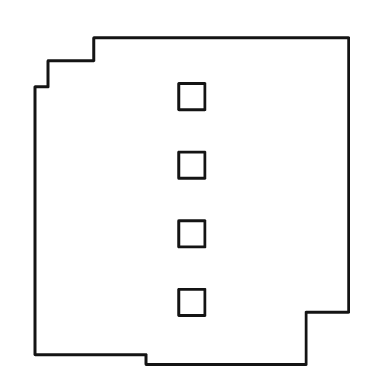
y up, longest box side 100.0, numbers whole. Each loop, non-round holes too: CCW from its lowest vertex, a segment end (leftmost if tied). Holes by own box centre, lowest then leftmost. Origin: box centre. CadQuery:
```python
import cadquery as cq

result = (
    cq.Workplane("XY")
    .moveTo(-14.0, -50.0)
    .lineTo(35.0, -50.0)
    .lineTo(35.0, -34.0)
    .lineTo(48.0, -34.0)
    .lineTo(48.0, 50.0)
    .lineTo(-30.0, 50.0)
    .lineTo(-30.0, 43.0)
    .lineTo(-44.0, 43.0)
    .lineTo(-44.0, 35.0)
    .lineTo(-48.0, 35.0)
    .lineTo(-48.0, -47.0)
    .lineTo(-14.0, -47.0)
    .close()
    .moveTo(-4.0, -35.0)
    .lineTo(4.0, -35.0)
    .lineTo(4.0, -27.0)
    .lineTo(-4.0, -27.0)
    .close()
    .moveTo(-4.0, -14.0)
    .lineTo(4.0, -14.0)
    .lineTo(4.0, -6.0)
    .lineTo(-4.0, -6.0)
    .close()
    .moveTo(-4.0, 7.0)
    .lineTo(4.0, 7.0)
    .lineTo(4.0, 15.0)
    .lineTo(-4.0, 15.0)
    .close()
    .moveTo(-4.0, 28.0)
    .lineTo(4.0, 28.0)
    .lineTo(4.0, 36.0)
    .lineTo(-4.0, 36.0)
    .close()
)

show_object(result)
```